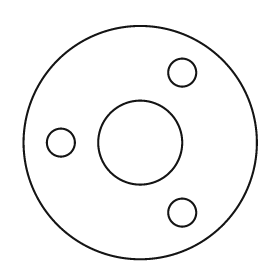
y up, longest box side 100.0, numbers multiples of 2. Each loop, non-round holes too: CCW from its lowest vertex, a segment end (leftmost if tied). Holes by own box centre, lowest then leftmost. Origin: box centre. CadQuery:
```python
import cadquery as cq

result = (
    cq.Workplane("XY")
    .moveTo(0.0, 0.0)
    .circle(50.0)
    .moveTo(18.0, -30.0)
    .circle(6.0)
    .moveTo(-34.0, 0.0)
    .circle(6.0)
    .moveTo(0.0, 0.0)
    .circle(18.0)
    .moveTo(18.0, 30.0)
    .circle(6.0)
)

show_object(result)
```